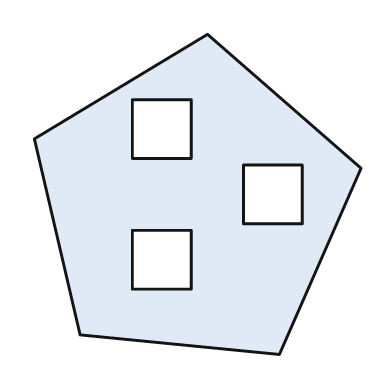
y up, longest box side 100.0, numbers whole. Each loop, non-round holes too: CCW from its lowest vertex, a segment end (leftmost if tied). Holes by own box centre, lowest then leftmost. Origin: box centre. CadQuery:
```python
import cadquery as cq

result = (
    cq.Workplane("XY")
    .moveTo(25.0, -49.0)
    .lineTo(50.0, 8.0)
    .lineTo(3.0, 49.0)
    .lineTo(-50.0, 17.0)
    .lineTo(-36.0, -43.0)
    .close()
    .moveTo(-20.0, -29.0)
    .lineTo(-2.0, -29.0)
    .lineTo(-2.0, -11.0)
    .lineTo(-20.0, -11.0)
    .close()
    .moveTo(14.0, -9.0)
    .lineTo(32.0, -9.0)
    .lineTo(32.0, 9.0)
    .lineTo(14.0, 9.0)
    .close()
    .moveTo(-20.0, 11.0)
    .lineTo(-2.0, 11.0)
    .lineTo(-2.0, 29.0)
    .lineTo(-20.0, 29.0)
    .close()
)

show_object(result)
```